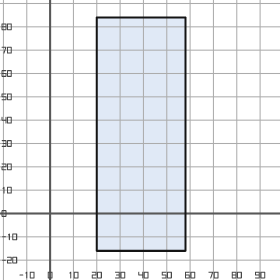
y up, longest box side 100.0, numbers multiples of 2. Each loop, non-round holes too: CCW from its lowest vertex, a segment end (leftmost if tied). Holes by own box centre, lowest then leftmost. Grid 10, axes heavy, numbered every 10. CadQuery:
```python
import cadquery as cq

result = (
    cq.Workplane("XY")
    .moveTo(20.0, -16.0)
    .lineTo(58.0, -16.0)
    .lineTo(58.0, 84.0)
    .lineTo(20.0, 84.0)
    .close()
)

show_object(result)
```